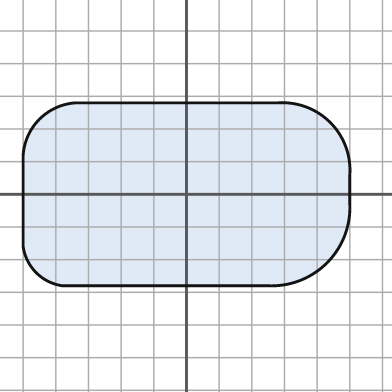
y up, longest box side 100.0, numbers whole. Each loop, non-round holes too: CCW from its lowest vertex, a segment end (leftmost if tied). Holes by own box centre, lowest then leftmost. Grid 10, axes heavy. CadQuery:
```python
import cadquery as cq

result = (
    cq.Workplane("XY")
    .moveTo(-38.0, -28.0)
    .lineTo(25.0, -28.0)
    .threePointArc((43.0, -21.0), (50.0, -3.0))
    .lineTo(50.0, 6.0)
    .threePointArc((44.0, 22.0), (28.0, 28.0))
    .lineTo(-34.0, 28.0)
    .threePointArc((-45.0, 23.0), (-50.0, 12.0))
    .lineTo(-50.0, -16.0)
    .threePointArc((-46.0, -24.0), (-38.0, -28.0))
    .close()
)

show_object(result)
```